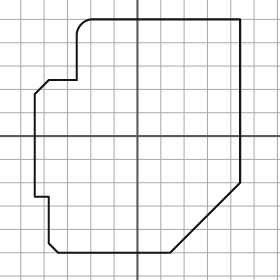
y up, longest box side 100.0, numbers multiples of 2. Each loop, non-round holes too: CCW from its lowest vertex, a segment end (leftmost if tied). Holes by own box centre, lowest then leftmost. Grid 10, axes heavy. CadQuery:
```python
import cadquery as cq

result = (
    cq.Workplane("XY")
    .moveTo(-34.0, -50.0)
    .lineTo(14.0, -50.0)
    .lineTo(44.0, -20.0)
    .lineTo(44.0, 50.0)
    .lineTo(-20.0, 50.0)
    .threePointArc((-24.0, 48.0), (-26.0, 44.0))
    .lineTo(-26.0, 24.0)
    .lineTo(-38.0, 24.0)
    .lineTo(-44.0, 18.0)
    .lineTo(-44.0, -26.0)
    .lineTo(-38.0, -26.0)
    .lineTo(-38.0, -46.0)
    .close()
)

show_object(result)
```